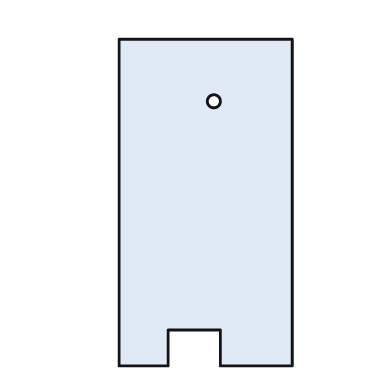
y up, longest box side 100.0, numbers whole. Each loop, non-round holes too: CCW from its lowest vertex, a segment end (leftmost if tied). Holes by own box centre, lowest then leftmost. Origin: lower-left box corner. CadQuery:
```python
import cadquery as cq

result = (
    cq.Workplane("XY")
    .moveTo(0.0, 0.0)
    .lineTo(15.0, 0.0)
    .lineTo(15.0, 11.0)
    .lineTo(31.0, 11.0)
    .lineTo(31.0, 0.0)
    .lineTo(53.0, 0.0)
    .lineTo(53.0, 100.0)
    .lineTo(0.0, 100.0)
    .close()
    .moveTo(29.0, 81.0)
    .circle(2.0)
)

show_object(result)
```